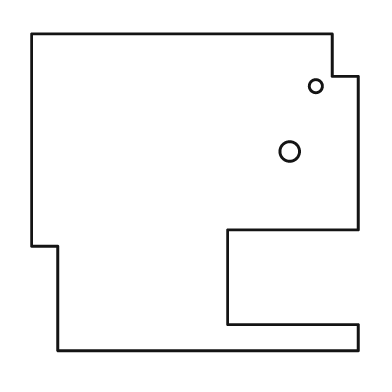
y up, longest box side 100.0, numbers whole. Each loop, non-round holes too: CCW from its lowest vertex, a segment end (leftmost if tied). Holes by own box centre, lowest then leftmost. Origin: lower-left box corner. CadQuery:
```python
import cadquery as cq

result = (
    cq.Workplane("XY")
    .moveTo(8.0, 0.0)
    .lineTo(100.0, 0.0)
    .lineTo(100.0, 8.0)
    .lineTo(60.0, 8.0)
    .lineTo(60.0, 37.0)
    .lineTo(100.0, 37.0)
    .lineTo(100.0, 84.0)
    .lineTo(92.0, 84.0)
    .lineTo(92.0, 97.0)
    .lineTo(0.0, 97.0)
    .lineTo(0.0, 32.0)
    .lineTo(8.0, 32.0)
    .close()
    .moveTo(79.0, 61.0)
    .circle(3.0)
    .moveTo(87.0, 81.0)
    .circle(2.0)
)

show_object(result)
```